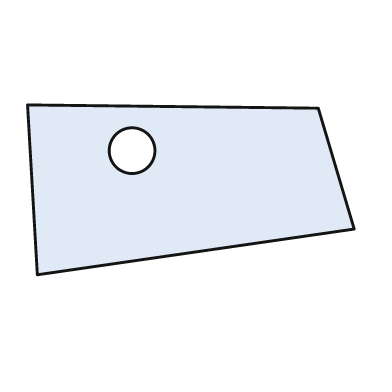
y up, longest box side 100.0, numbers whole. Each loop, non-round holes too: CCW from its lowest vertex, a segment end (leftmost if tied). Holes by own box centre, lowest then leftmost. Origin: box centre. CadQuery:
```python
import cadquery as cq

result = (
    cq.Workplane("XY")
    .moveTo(-47.0, -26.0)
    .lineTo(50.0, -12.0)
    .lineTo(39.0, 25.0)
    .lineTo(-50.0, 26.0)
    .close()
    .moveTo(-18.0, 12.0)
    .circle(7.0)
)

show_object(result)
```